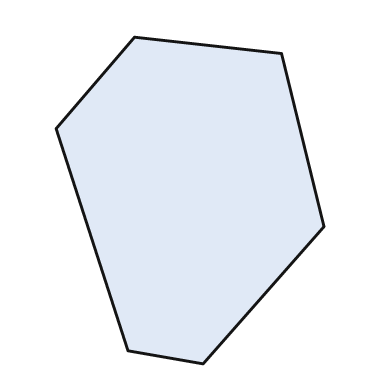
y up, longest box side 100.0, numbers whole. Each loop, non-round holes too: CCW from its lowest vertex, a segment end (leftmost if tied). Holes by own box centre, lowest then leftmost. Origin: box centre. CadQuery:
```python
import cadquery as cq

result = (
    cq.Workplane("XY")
    .moveTo(4.0, -50.0)
    .lineTo(41.0, -8.0)
    .lineTo(28.0, 45.0)
    .lineTo(-17.0, 50.0)
    .lineTo(-41.0, 22.0)
    .lineTo(-19.0, -46.0)
    .close()
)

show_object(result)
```